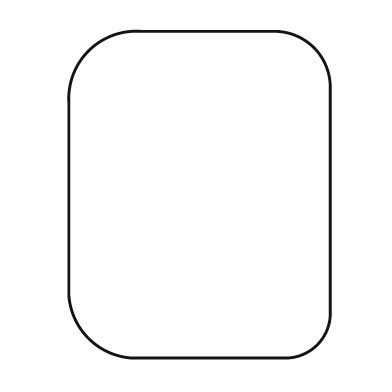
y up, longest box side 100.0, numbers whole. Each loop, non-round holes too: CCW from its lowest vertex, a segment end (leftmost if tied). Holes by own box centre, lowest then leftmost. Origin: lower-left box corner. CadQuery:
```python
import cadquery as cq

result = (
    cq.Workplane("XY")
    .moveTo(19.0, 0.0)
    .lineTo(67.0, 0.0)
    .threePointArc((76.0, 4.0), (80.0, 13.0))
    .lineTo(80.0, 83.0)
    .threePointArc((75.0, 95.0), (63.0, 100.0))
    .lineTo(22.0, 100.0)
    .threePointArc((6.0, 94.0), (0.0, 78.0))
    .lineTo(0.0, 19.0)
    .threePointArc((6.0, 6.0), (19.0, 0.0))
    .close()
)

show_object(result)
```